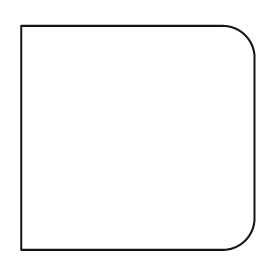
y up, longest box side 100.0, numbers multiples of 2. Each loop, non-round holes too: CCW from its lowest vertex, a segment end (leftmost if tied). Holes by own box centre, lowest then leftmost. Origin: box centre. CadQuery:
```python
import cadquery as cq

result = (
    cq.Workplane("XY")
    .moveTo(-50.0, -48.0)
    .lineTo(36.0, -48.0)
    .threePointArc((46.0, -44.0), (50.0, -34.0))
    .lineTo(50.0, 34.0)
    .threePointArc((46.0, 44.0), (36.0, 48.0))
    .lineTo(-50.0, 48.0)
    .close()
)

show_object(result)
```